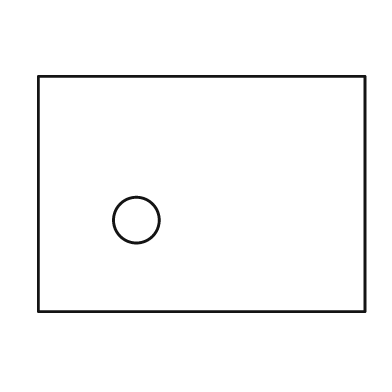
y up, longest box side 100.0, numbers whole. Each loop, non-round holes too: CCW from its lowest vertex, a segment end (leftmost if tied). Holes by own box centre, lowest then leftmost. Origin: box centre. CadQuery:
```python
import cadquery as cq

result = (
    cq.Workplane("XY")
    .moveTo(-50.0, -36.0)
    .lineTo(50.0, -36.0)
    .lineTo(50.0, 36.0)
    .lineTo(-50.0, 36.0)
    .close()
    .moveTo(-20.0, -8.0)
    .circle(7.0)
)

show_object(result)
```